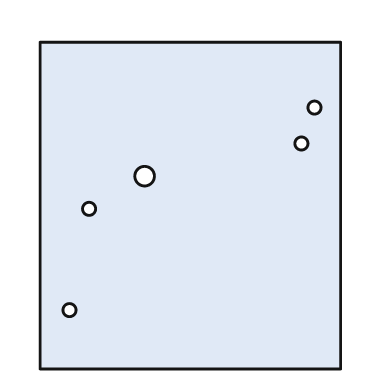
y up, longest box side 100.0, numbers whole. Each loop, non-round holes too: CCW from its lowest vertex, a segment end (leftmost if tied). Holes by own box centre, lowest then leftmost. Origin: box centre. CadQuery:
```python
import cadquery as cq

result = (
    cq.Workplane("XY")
    .moveTo(-46.0, -50.0)
    .lineTo(46.0, -50.0)
    .lineTo(46.0, 50.0)
    .lineTo(-46.0, 50.0)
    .close()
    .moveTo(-37.0, -32.0)
    .circle(2.0)
    .moveTo(-31.0, -1.0)
    .circle(2.0)
    .moveTo(-14.0, 9.0)
    .circle(3.0)
    .moveTo(34.0, 19.0)
    .circle(2.0)
    .moveTo(38.0, 30.0)
    .circle(2.0)
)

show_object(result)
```